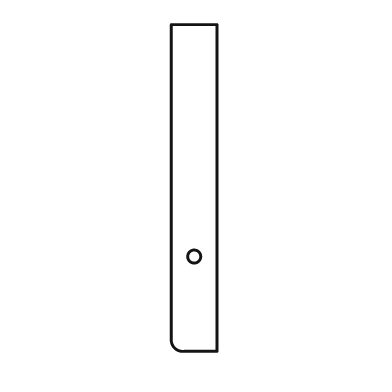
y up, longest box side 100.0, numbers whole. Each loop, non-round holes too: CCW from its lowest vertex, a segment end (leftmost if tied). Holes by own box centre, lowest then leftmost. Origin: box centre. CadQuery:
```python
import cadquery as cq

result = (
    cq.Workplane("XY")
    .moveTo(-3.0, -50.0)
    .lineTo(7.0, -50.0)
    .lineTo(7.0, 50.0)
    .lineTo(-7.0, 50.0)
    .lineTo(-7.0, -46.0)
    .threePointArc((-6.0, -49.0), (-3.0, -50.0))
    .close()
    .moveTo(0.0, -21.0)
    .circle(2.0)
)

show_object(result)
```